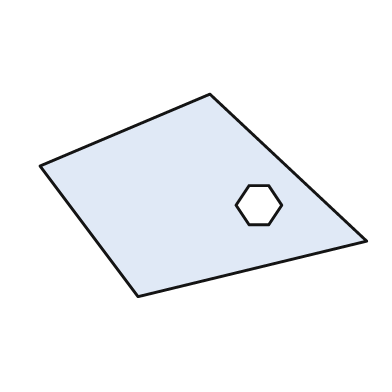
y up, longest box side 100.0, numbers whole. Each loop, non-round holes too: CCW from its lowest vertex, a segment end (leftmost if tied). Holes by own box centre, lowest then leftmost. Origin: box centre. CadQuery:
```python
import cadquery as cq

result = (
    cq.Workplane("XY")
    .moveTo(-20.0, -31.0)
    .lineTo(50.0, -14.0)
    .lineTo(2.0, 31.0)
    .lineTo(-50.0, 9.0)
    .close()
    .moveTo(14.0, -9.0)
    .lineTo(20.0, -9.0)
    .lineTo(24.0, -3.0)
    .lineTo(20.0, 3.0)
    .lineTo(14.0, 3.0)
    .lineTo(10.0, -3.0)
    .close()
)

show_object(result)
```